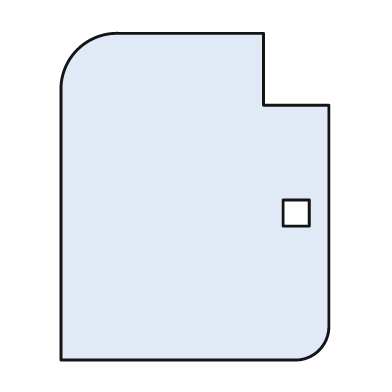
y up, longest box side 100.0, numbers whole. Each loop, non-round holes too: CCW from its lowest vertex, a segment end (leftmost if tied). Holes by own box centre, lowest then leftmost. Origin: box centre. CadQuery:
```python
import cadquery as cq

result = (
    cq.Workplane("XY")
    .moveTo(-41.0, -50.0)
    .lineTo(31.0, -50.0)
    .threePointArc((38.0, -47.0), (41.0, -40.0))
    .lineTo(41.0, 28.0)
    .lineTo(21.0, 28.0)
    .lineTo(21.0, 50.0)
    .lineTo(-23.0, 50.0)
    .threePointArc((-36.0, 45.0), (-41.0, 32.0))
    .close()
    .moveTo(27.0, -9.0)
    .lineTo(35.0, -9.0)
    .lineTo(35.0, -1.0)
    .lineTo(27.0, -1.0)
    .close()
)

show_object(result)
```